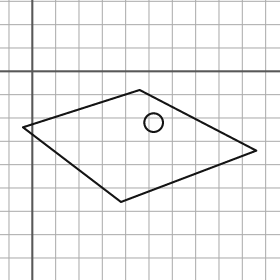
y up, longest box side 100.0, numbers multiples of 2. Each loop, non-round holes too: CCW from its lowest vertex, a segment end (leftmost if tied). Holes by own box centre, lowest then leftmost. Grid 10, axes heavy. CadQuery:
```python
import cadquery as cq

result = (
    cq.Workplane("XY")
    .moveTo(38.0, -56.0)
    .lineTo(96.0, -34.0)
    .lineTo(46.0, -8.0)
    .lineTo(-4.0, -24.0)
    .close()
    .moveTo(52.0, -22.0)
    .circle(4.0)
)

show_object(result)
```